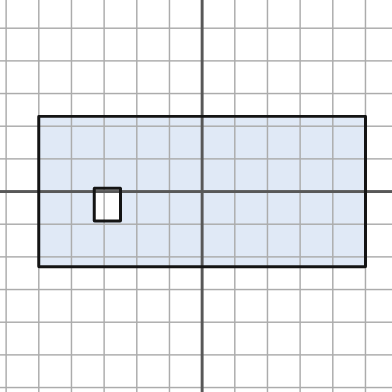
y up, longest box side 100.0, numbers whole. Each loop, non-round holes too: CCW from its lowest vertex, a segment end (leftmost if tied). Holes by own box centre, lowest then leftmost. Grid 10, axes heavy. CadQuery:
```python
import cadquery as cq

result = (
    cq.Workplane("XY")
    .moveTo(-50.0, -23.0)
    .lineTo(50.0, -23.0)
    .lineTo(50.0, 23.0)
    .lineTo(-50.0, 23.0)
    .close()
    .moveTo(-33.0, -9.0)
    .lineTo(-25.0, -9.0)
    .lineTo(-25.0, 1.0)
    .lineTo(-33.0, 1.0)
    .close()
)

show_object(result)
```